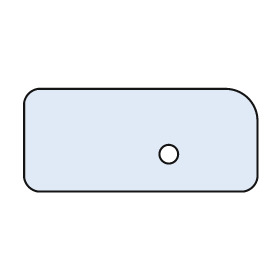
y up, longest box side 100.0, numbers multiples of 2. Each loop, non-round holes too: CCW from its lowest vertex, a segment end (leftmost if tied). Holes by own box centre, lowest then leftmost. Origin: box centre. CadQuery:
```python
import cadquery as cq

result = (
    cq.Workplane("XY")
    .moveTo(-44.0, -22.0)
    .lineTo(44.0, -22.0)
    .threePointArc((48.0, -20.0), (50.0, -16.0))
    .lineTo(50.0, 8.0)
    .threePointArc((46.0, 18.0), (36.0, 22.0))
    .lineTo(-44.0, 22.0)
    .threePointArc((-48.0, 20.0), (-50.0, 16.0))
    .lineTo(-50.0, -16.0)
    .threePointArc((-48.0, -20.0), (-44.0, -22.0))
    .close()
    .moveTo(12.0, -6.0)
    .circle(4.0)
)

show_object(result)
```